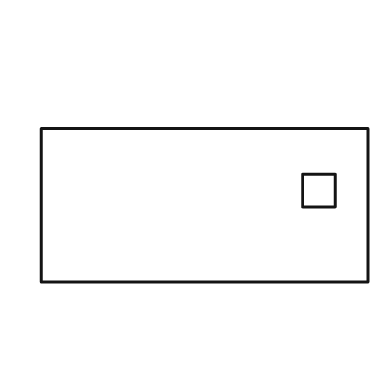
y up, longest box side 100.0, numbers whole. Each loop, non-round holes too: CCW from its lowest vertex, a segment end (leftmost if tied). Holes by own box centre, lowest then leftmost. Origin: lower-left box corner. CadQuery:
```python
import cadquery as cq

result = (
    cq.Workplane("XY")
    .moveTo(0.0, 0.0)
    .lineTo(100.0, 0.0)
    .lineTo(100.0, 47.0)
    .lineTo(0.0, 47.0)
    .close()
    .moveTo(80.0, 23.0)
    .lineTo(90.0, 23.0)
    .lineTo(90.0, 33.0)
    .lineTo(80.0, 33.0)
    .close()
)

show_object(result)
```